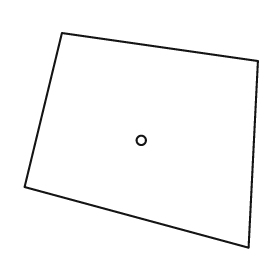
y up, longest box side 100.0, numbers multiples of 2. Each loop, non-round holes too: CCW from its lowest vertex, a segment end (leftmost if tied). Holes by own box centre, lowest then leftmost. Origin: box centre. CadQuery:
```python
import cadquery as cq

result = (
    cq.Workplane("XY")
    .moveTo(46.0, -46.0)
    .lineTo(50.0, 34.0)
    .lineTo(-34.0, 46.0)
    .lineTo(-50.0, -20.0)
    .close()
    .moveTo(0.0, 0.0)
    .circle(2.0)
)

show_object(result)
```